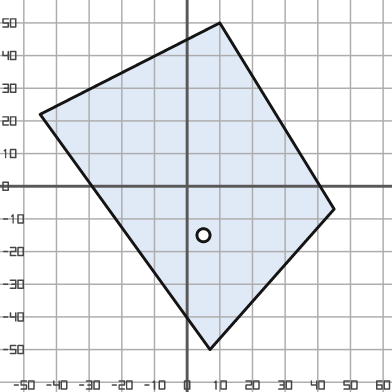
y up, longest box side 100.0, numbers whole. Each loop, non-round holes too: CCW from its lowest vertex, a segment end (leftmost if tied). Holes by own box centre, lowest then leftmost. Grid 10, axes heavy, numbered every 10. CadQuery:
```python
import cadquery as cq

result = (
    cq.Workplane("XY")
    .moveTo(7.0, -50.0)
    .lineTo(45.0, -7.0)
    .lineTo(10.0, 50.0)
    .lineTo(-45.0, 22.0)
    .close()
    .moveTo(5.0, -15.0)
    .circle(2.0)
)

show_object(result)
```